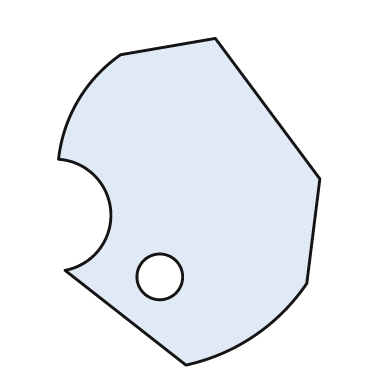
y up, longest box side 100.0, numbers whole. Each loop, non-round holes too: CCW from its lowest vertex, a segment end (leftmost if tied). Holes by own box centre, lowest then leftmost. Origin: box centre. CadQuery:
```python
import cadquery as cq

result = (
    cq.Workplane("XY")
    .moveTo(-1.0, -50.0)
    .threePointArc((20.0, -41.0), (36.0, -25.0))
    .lineTo(40.0, 7.0)
    .lineTo(8.0, 50.0)
    .lineTo(-21.0, 45.0)
    .threePointArc((-34.0, 31.0), (-40.0, 13.0))
    .threePointArc((-24.0, -3.0), (-38.0, -21.0))
    .close()
    .moveTo(-9.0, -23.0)
    .circle(7.0)
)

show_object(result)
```